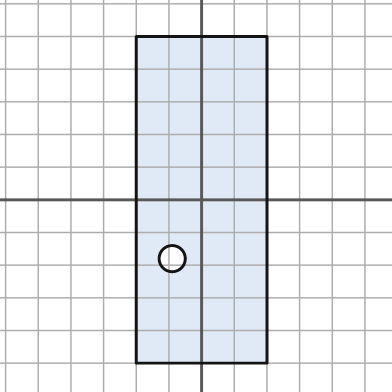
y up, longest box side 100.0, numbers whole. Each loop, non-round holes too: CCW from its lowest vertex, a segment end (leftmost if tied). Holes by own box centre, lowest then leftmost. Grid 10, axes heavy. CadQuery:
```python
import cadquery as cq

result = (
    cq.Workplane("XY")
    .moveTo(-20.0, -50.0)
    .lineTo(20.0, -50.0)
    .lineTo(20.0, 50.0)
    .lineTo(-20.0, 50.0)
    .close()
    .moveTo(-9.0, -18.0)
    .circle(4.0)
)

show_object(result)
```